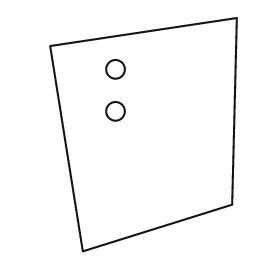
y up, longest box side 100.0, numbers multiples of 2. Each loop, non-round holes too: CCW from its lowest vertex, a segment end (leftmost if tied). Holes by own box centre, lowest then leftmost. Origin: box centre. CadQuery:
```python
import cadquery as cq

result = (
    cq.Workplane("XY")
    .moveTo(-26.0, -50.0)
    .lineTo(38.0, -30.0)
    .lineTo(40.0, 50.0)
    .lineTo(-40.0, 38.0)
    .close()
    .moveTo(-12.0, 10.0)
    .circle(4.0)
    .moveTo(-12.0, 28.0)
    .circle(4.0)
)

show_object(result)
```